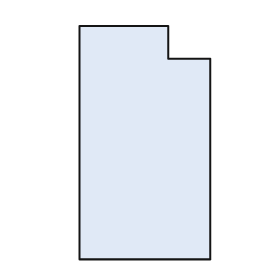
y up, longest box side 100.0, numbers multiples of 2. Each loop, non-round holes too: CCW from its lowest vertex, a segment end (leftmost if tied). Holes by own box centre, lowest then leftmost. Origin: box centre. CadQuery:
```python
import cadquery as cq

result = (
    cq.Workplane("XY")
    .moveTo(-28.0, -50.0)
    .lineTo(28.0, -50.0)
    .lineTo(28.0, 36.0)
    .lineTo(10.0, 36.0)
    .lineTo(10.0, 50.0)
    .lineTo(-28.0, 50.0)
    .close()
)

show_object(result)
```